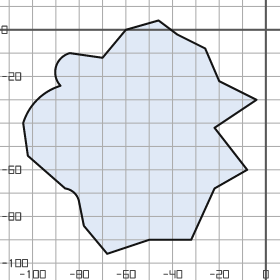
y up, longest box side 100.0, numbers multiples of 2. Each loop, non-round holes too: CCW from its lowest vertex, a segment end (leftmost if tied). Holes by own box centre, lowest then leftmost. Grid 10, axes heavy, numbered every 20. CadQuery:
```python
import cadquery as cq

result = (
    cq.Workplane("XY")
    .moveTo(-68.0, -96.0)
    .lineTo(-50.0, -90.0)
    .lineTo(-32.0, -90.0)
    .lineTo(-22.0, -68.0)
    .lineTo(-8.0, -60.0)
    .lineTo(-22.0, -42.0)
    .lineTo(-4.0, -30.0)
    .lineTo(-20.0, -22.0)
    .lineTo(-26.0, -8.0)
    .lineTo(-38.0, -2.0)
    .lineTo(-46.0, 4.0)
    .lineTo(-60.0, 0.0)
    .lineTo(-70.0, -12.0)
    .lineTo(-84.0, -10.0)
    .threePointArc((-90.0, -16.0), (-88.0, -24.0))
    .threePointArc((-98.0, -30.0), (-104.0, -40.0))
    .lineTo(-102.0, -54.0)
    .lineTo(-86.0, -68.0)
    .threePointArc((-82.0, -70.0), (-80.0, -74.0))
    .lineTo(-78.0, -84.0)
    .close()
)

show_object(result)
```